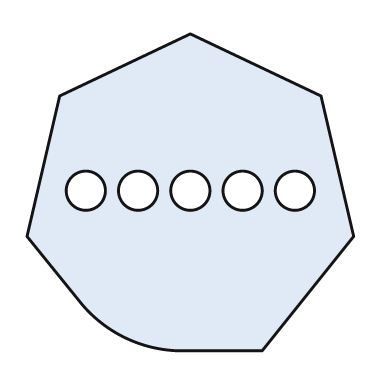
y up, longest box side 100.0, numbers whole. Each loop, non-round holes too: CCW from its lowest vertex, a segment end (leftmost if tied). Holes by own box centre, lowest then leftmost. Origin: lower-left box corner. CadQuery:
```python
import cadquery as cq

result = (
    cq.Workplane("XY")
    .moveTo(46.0, 0.0)
    .lineTo(72.0, 0.0)
    .lineTo(100.0, 35.0)
    .lineTo(90.0, 78.0)
    .lineTo(50.0, 97.0)
    .lineTo(10.0, 78.0)
    .lineTo(0.0, 35.0)
    .lineTo(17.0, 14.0)
    .threePointArc((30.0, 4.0), (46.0, 0.0))
    .close()
    .moveTo(18.0, 49.0)
    .circle(6.0)
    .moveTo(34.0, 49.0)
    .circle(6.0)
    .moveTo(50.0, 49.0)
    .circle(6.0)
    .moveTo(66.0, 49.0)
    .circle(6.0)
    .moveTo(82.0, 49.0)
    .circle(6.0)
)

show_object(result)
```